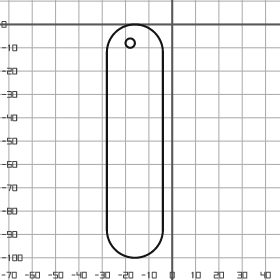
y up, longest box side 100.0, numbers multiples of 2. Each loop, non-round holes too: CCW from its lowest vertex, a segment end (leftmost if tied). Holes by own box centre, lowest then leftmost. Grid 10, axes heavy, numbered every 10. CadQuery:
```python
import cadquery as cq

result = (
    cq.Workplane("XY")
    .moveTo(-28.0, -88.0)
    .threePointArc((-16.0, -100.0), (-4.0, -88.0))
    .lineTo(-4.0, -12.0)
    .threePointArc((-16.0, 0.0), (-28.0, -12.0))
    .close()
    .moveTo(-18.0, -8.0)
    .circle(2.0)
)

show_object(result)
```